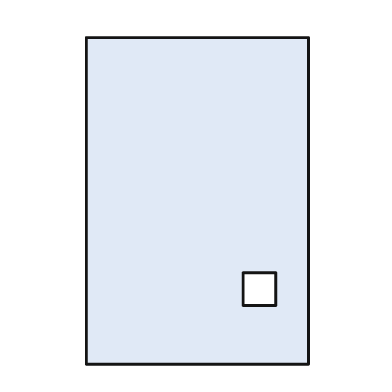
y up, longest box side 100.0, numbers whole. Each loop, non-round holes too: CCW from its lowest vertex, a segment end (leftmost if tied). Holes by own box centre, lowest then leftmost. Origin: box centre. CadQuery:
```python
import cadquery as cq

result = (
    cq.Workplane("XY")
    .moveTo(-34.0, -50.0)
    .lineTo(34.0, -50.0)
    .lineTo(34.0, 50.0)
    .lineTo(-34.0, 50.0)
    .close()
    .moveTo(14.0, -32.0)
    .lineTo(24.0, -32.0)
    .lineTo(24.0, -22.0)
    .lineTo(14.0, -22.0)
    .close()
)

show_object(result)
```